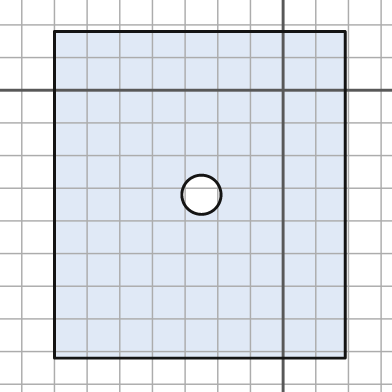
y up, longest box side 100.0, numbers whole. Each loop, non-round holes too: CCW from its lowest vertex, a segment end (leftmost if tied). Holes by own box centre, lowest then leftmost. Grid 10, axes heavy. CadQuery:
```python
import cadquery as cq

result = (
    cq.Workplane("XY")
    .moveTo(-70.0, -82.0)
    .lineTo(19.0, -82.0)
    .lineTo(19.0, 18.0)
    .lineTo(-70.0, 18.0)
    .close()
    .moveTo(-25.0, -32.0)
    .circle(6.0)
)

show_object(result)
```